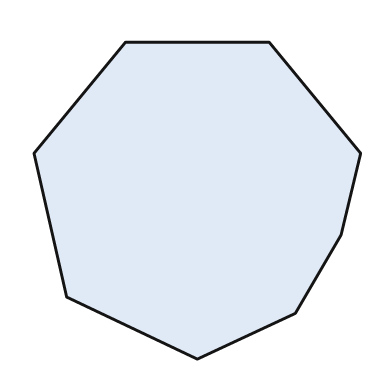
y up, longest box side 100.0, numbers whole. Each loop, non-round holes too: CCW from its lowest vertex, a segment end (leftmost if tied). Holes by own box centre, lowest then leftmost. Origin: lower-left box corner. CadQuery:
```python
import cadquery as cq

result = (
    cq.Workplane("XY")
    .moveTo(50.0, 0.0)
    .lineTo(80.0, 14.0)
    .lineTo(94.0, 38.0)
    .lineTo(100.0, 63.0)
    .lineTo(72.0, 97.0)
    .lineTo(28.0, 97.0)
    .lineTo(0.0, 63.0)
    .lineTo(10.0, 19.0)
    .close()
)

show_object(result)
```